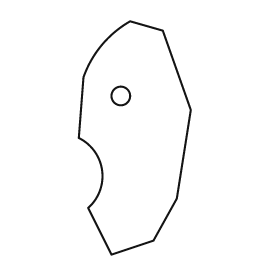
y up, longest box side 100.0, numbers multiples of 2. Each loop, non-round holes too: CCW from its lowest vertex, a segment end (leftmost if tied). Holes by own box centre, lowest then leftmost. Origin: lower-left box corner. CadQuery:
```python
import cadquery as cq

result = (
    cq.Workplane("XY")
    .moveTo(14.0, 0.0)
    .lineTo(32.0, 6.0)
    .lineTo(42.0, 24.0)
    .lineTo(48.0, 62.0)
    .lineTo(36.0, 96.0)
    .lineTo(22.0, 100.0)
    .threePointArc((10.0, 90.0), (2.0, 76.0))
    .lineTo(0.0, 50.0)
    .threePointArc((10.0, 36.0), (4.0, 20.0))
    .close()
    .moveTo(18.0, 68.0)
    .circle(4.0)
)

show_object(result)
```